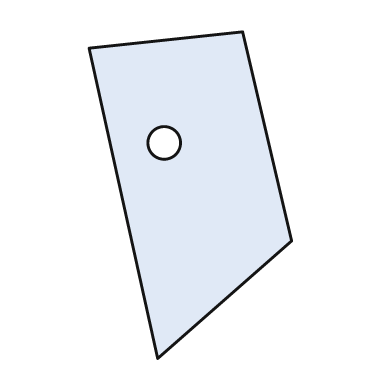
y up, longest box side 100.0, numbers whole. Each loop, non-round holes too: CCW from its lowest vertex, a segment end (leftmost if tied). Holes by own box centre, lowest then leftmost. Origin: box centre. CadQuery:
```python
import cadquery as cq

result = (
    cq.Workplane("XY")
    .moveTo(-10.0, -50.0)
    .lineTo(31.0, -14.0)
    .lineTo(16.0, 50.0)
    .lineTo(-31.0, 45.0)
    .close()
    .moveTo(-8.0, 16.0)
    .circle(5.0)
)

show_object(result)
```